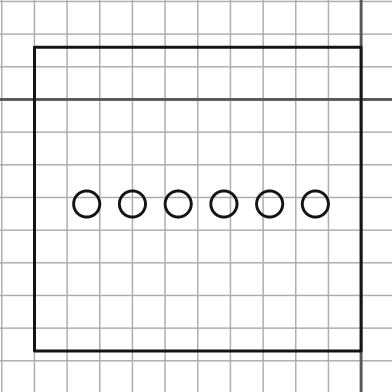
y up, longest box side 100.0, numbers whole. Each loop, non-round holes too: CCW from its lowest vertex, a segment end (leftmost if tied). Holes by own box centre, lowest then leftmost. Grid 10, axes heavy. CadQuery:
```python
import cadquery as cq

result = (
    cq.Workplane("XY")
    .moveTo(-100.0, -77.0)
    .lineTo(0.0, -77.0)
    .lineTo(0.0, 16.0)
    .lineTo(-100.0, 16.0)
    .close()
    .moveTo(-84.0, -32.0)
    .circle(4.0)
    .moveTo(-70.0, -32.0)
    .circle(4.0)
    .moveTo(-56.0, -32.0)
    .circle(4.0)
    .moveTo(-42.0, -32.0)
    .circle(4.0)
    .moveTo(-28.0, -32.0)
    .circle(4.0)
    .moveTo(-14.0, -32.0)
    .circle(4.0)
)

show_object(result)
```